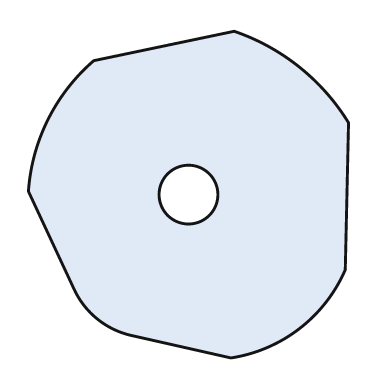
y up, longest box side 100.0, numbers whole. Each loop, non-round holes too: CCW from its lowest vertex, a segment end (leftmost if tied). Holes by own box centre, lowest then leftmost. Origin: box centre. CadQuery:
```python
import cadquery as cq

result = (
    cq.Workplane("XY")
    .moveTo(13.0, -50.0)
    .threePointArc((34.0, -41.0), (48.0, -23.0))
    .lineTo(49.0, 22.0)
    .threePointArc((34.0, 39.0), (14.0, 50.0))
    .lineTo(-29.0, 41.0)
    .threePointArc((-43.0, 23.0), (-49.0, 1.0))
    .lineTo(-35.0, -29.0)
    .threePointArc((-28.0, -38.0), (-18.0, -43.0))
    .close()
    .moveTo(0.0, 0.0)
    .circle(9.0)
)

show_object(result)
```